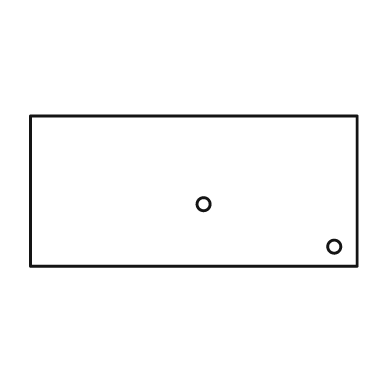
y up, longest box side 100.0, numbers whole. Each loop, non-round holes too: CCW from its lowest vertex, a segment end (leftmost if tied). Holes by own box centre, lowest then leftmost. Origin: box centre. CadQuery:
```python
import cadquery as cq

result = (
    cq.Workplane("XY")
    .moveTo(-50.0, -23.0)
    .lineTo(50.0, -23.0)
    .lineTo(50.0, 23.0)
    .lineTo(-50.0, 23.0)
    .close()
    .moveTo(43.0, -17.0)
    .circle(2.0)
    .moveTo(3.0, -4.0)
    .circle(2.0)
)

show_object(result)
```